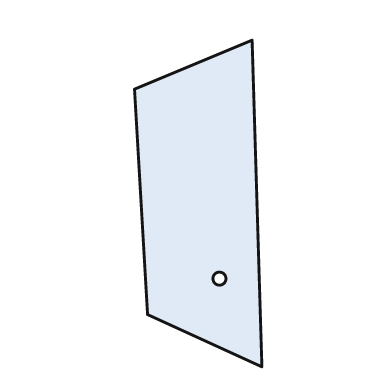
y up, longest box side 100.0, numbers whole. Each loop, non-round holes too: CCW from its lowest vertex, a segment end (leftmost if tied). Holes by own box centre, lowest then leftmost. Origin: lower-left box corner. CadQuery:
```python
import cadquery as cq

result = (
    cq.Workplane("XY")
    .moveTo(39.0, 0.0)
    .lineTo(36.0, 100.0)
    .lineTo(0.0, 85.0)
    .lineTo(4.0, 16.0)
    .close()
    .moveTo(26.0, 27.0)
    .circle(2.0)
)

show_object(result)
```